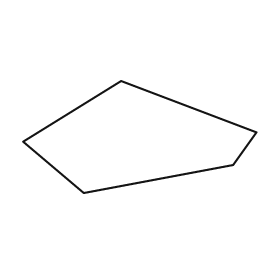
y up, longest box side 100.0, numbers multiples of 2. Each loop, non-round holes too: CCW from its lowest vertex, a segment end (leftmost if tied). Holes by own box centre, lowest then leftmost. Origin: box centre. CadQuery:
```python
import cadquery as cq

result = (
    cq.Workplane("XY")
    .moveTo(-24.0, -24.0)
    .lineTo(40.0, -12.0)
    .lineTo(50.0, 2.0)
    .lineTo(-8.0, 24.0)
    .lineTo(-50.0, -2.0)
    .close()
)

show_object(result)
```